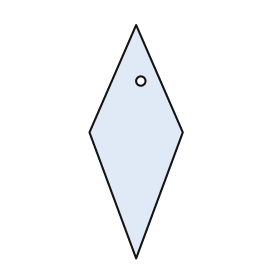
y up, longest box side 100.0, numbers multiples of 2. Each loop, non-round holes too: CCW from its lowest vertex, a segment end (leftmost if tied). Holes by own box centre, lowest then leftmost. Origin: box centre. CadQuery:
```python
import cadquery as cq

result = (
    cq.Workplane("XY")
    .moveTo(0.0, -50.0)
    .lineTo(20.0, 4.0)
    .lineTo(0.0, 50.0)
    .lineTo(-20.0, 4.0)
    .close()
    .moveTo(2.0, 26.0)
    .circle(2.0)
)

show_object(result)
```